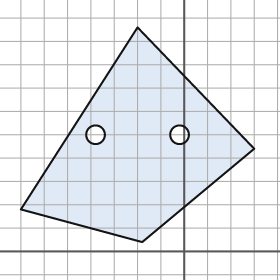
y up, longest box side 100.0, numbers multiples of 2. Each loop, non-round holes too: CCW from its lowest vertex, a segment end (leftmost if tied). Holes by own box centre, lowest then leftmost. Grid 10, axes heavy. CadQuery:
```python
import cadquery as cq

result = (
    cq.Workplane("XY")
    .moveTo(-18.0, 4.0)
    .lineTo(30.0, 44.0)
    .lineTo(-20.0, 96.0)
    .lineTo(-70.0, 18.0)
    .close()
    .moveTo(-38.0, 50.0)
    .circle(4.0)
    .moveTo(-2.0, 50.0)
    .circle(4.0)
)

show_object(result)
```